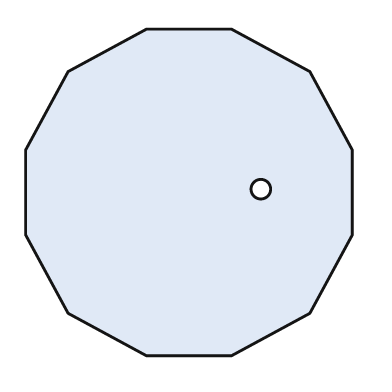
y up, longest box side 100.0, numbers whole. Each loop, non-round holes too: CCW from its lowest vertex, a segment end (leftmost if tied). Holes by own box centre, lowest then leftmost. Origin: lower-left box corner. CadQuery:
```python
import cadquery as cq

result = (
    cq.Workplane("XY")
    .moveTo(37.0, 0.0)
    .lineTo(63.0, 0.0)
    .lineTo(87.0, 13.0)
    .lineTo(100.0, 37.0)
    .lineTo(100.0, 63.0)
    .lineTo(87.0, 87.0)
    .lineTo(63.0, 100.0)
    .lineTo(37.0, 100.0)
    .lineTo(13.0, 87.0)
    .lineTo(0.0, 63.0)
    .lineTo(0.0, 37.0)
    .lineTo(13.0, 13.0)
    .close()
    .moveTo(72.0, 51.0)
    .circle(3.0)
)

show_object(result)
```